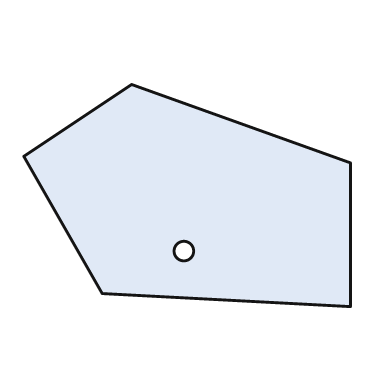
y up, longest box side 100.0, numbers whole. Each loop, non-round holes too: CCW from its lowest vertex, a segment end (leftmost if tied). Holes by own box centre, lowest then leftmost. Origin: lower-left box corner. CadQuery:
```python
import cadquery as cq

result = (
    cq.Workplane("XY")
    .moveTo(100.0, 0.0)
    .lineTo(100.0, 44.0)
    .lineTo(33.0, 68.0)
    .lineTo(0.0, 46.0)
    .lineTo(24.0, 4.0)
    .close()
    .moveTo(49.0, 17.0)
    .circle(3.0)
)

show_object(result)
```